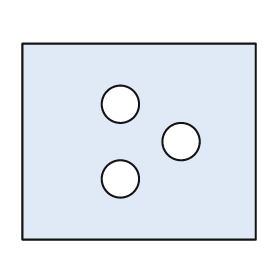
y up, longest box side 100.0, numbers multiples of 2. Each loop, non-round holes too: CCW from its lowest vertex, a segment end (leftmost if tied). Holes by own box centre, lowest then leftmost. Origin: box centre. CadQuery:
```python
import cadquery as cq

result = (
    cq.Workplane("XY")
    .moveTo(-50.0, -42.0)
    .lineTo(50.0, -42.0)
    .lineTo(50.0, 42.0)
    .lineTo(-50.0, 42.0)
    .close()
    .moveTo(-8.0, -16.0)
    .circle(8.0)
    .moveTo(18.0, 0.0)
    .circle(8.0)
    .moveTo(-8.0, 16.0)
    .circle(8.0)
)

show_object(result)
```